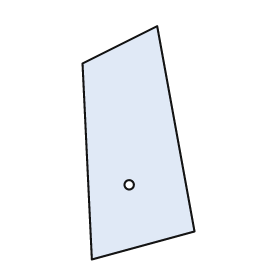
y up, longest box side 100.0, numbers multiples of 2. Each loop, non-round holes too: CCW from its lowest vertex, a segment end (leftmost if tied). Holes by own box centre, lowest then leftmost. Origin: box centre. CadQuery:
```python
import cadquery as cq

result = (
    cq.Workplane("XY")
    .moveTo(-20.0, -50.0)
    .lineTo(24.0, -38.0)
    .lineTo(8.0, 50.0)
    .lineTo(-24.0, 34.0)
    .close()
    .moveTo(-4.0, -18.0)
    .circle(2.0)
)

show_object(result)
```